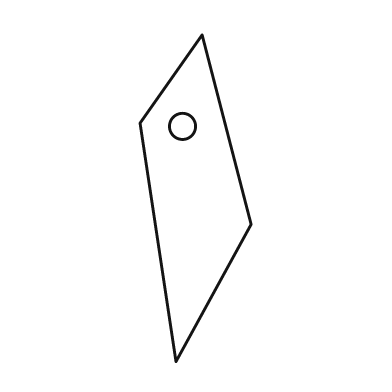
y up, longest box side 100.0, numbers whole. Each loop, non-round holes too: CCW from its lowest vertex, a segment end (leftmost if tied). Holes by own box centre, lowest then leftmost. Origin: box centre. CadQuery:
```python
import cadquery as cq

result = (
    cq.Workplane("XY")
    .moveTo(-6.0, -50.0)
    .lineTo(17.0, -8.0)
    .lineTo(2.0, 50.0)
    .lineTo(-17.0, 23.0)
    .close()
    .moveTo(-4.0, 22.0)
    .circle(4.0)
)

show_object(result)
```